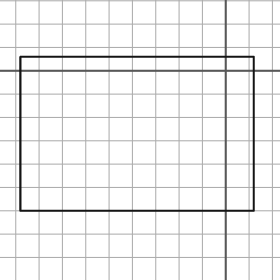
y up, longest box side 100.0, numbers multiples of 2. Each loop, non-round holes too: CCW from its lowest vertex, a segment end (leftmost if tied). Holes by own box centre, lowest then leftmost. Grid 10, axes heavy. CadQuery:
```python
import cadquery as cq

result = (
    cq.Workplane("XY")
    .moveTo(-88.0, -60.0)
    .lineTo(12.0, -60.0)
    .lineTo(12.0, 6.0)
    .lineTo(-88.0, 6.0)
    .close()
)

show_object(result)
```